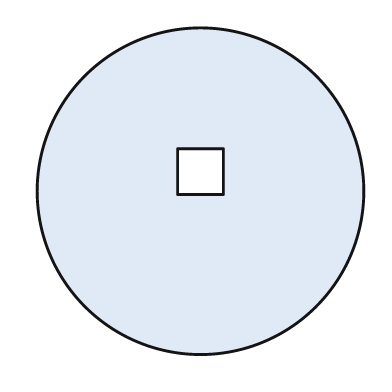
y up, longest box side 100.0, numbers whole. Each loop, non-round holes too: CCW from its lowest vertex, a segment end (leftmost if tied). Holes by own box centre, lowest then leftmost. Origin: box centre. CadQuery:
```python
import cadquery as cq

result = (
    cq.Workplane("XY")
    .moveTo(0.0, 0.0)
    .circle(50.0)
    .moveTo(-7.0, -1.0)
    .lineTo(7.0, -1.0)
    .lineTo(7.0, 13.0)
    .lineTo(-7.0, 13.0)
    .close()
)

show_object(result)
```